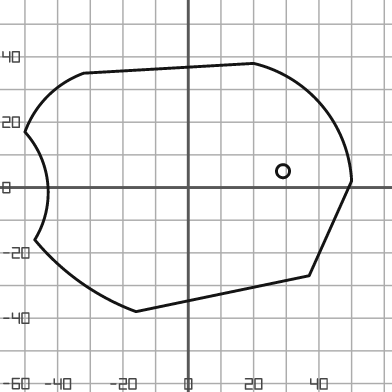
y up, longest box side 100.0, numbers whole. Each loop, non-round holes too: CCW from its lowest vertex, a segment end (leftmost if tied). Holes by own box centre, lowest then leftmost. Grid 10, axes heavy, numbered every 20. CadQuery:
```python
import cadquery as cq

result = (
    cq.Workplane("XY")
    .moveTo(-16.0, -38.0)
    .lineTo(37.0, -27.0)
    .lineTo(50.0, 2.0)
    .threePointArc((41.0, 25.0), (20.0, 38.0))
    .lineTo(-32.0, 35.0)
    .threePointArc((-43.0, 28.0), (-50.0, 17.0))
    .threePointArc((-43.0, 1.0), (-47.0, -16.0))
    .threePointArc((-33.0, -29.0), (-16.0, -38.0))
    .close()
    .moveTo(29.0, 5.0)
    .circle(2.0)
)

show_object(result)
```